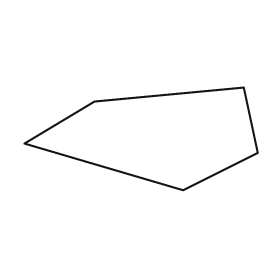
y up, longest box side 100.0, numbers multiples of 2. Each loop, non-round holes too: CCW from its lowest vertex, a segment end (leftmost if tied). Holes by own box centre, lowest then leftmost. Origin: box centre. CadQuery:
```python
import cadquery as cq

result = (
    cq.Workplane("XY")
    .moveTo(18.0, -22.0)
    .lineTo(50.0, -6.0)
    .lineTo(44.0, 22.0)
    .lineTo(-20.0, 16.0)
    .lineTo(-50.0, -2.0)
    .close()
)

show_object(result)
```